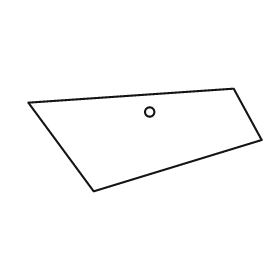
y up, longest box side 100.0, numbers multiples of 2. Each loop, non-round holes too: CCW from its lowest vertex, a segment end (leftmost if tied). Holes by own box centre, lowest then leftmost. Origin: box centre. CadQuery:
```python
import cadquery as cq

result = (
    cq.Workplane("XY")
    .moveTo(-22.0, -22.0)
    .lineTo(50.0, 0.0)
    .lineTo(38.0, 22.0)
    .lineTo(-50.0, 16.0)
    .close()
    .moveTo(2.0, 12.0)
    .circle(2.0)
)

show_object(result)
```